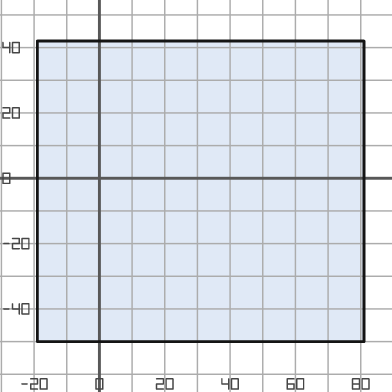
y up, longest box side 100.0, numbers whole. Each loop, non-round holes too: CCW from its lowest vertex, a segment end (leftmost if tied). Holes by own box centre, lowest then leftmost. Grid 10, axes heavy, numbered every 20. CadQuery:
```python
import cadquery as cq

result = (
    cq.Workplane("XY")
    .moveTo(-19.0, -50.0)
    .lineTo(81.0, -50.0)
    .lineTo(81.0, 42.0)
    .lineTo(-19.0, 42.0)
    .close()
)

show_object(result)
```